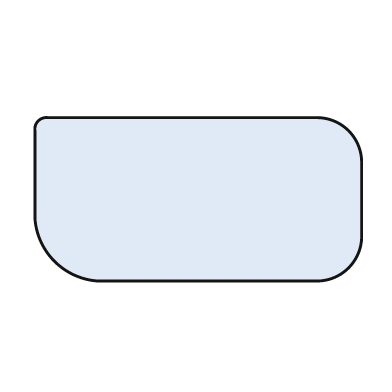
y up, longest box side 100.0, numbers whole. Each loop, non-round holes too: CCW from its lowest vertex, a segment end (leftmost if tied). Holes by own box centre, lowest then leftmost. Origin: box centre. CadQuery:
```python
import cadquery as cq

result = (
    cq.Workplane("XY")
    .moveTo(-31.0, -25.0)
    .lineTo(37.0, -25.0)
    .threePointArc((46.0, -21.0), (50.0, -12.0))
    .lineTo(50.0, 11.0)
    .threePointArc((46.0, 21.0), (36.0, 25.0))
    .lineTo(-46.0, 25.0)
    .threePointArc((-49.0, 24.0), (-50.0, 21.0))
    .lineTo(-50.0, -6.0)
    .threePointArc((-44.0, -19.0), (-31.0, -25.0))
    .close()
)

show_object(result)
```